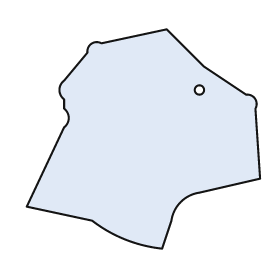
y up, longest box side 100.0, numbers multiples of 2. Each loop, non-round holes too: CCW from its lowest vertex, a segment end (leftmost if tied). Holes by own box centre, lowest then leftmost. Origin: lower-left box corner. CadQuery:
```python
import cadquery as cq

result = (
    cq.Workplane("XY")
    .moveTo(58.0, 0.0)
    .lineTo(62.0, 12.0)
    .threePointArc((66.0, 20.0), (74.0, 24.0))
    .lineTo(100.0, 30.0)
    .lineTo(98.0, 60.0)
    .threePointArc((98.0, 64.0), (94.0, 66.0))
    .lineTo(76.0, 78.0)
    .lineTo(60.0, 94.0)
    .lineTo(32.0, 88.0)
    .threePointArc((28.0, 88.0), (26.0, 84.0))
    .lineTo(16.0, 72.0)
    .threePointArc((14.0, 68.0), (16.0, 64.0))
    .lineTo(16.0, 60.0)
    .threePointArc((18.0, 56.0), (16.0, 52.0))
    .lineTo(0.0, 18.0)
    .lineTo(28.0, 12.0)
    .threePointArc((42.0, 4.0), (58.0, 0.0))
    .close()
    .moveTo(74.0, 68.0)
    .circle(2.0)
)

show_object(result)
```